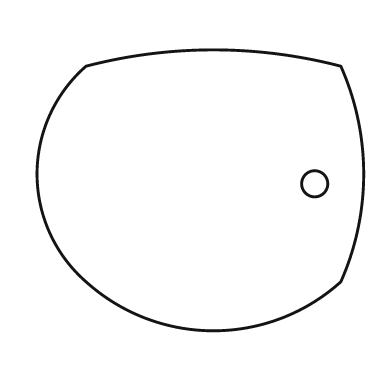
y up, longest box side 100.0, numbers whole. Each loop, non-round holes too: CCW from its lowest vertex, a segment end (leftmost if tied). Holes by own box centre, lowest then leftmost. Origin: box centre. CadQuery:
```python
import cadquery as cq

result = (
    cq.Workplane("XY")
    .moveTo(-35.0, -28.0)
    .threePointArc((4.0, -43.0), (43.0, -28.0))
    .threePointArc((50.0, 5.0), (43.0, 38.0))
    .threePointArc((4.0, 43.0), (-35.0, 38.0))
    .threePointArc((-50.0, 5.0), (-35.0, -28.0))
    .close()
    .moveTo(35.0, 2.0)
    .circle(4.0)
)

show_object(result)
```